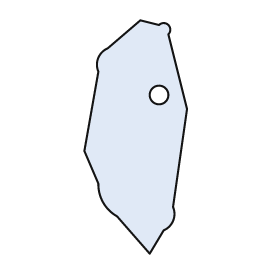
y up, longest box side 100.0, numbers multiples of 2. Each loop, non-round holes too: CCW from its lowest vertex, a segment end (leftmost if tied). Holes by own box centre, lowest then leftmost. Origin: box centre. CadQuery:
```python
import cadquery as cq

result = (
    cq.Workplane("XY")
    .moveTo(6.0, -50.0)
    .lineTo(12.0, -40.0)
    .threePointArc((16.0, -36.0), (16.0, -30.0))
    .lineTo(22.0, 12.0)
    .lineTo(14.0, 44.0)
    .threePointArc((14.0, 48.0), (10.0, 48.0))
    .lineTo(2.0, 50.0)
    .lineTo(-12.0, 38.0)
    .threePointArc((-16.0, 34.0), (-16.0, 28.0))
    .lineTo(-22.0, -6.0)
    .lineTo(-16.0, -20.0)
    .threePointArc((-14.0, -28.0), (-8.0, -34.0))
    .close()
    .moveTo(10.0, 18.0)
    .circle(4.0)
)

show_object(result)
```